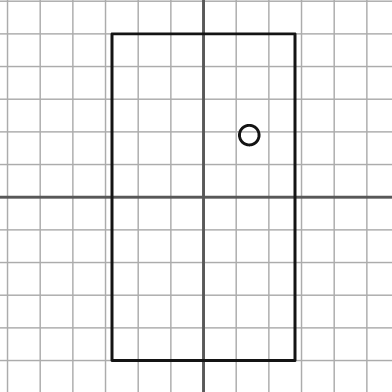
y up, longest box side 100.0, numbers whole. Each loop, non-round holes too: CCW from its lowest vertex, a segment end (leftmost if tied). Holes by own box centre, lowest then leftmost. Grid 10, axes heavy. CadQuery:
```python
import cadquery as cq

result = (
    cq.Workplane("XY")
    .moveTo(-28.0, -50.0)
    .lineTo(28.0, -50.0)
    .lineTo(28.0, 50.0)
    .lineTo(-28.0, 50.0)
    .close()
    .moveTo(14.0, 19.0)
    .circle(3.0)
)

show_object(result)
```